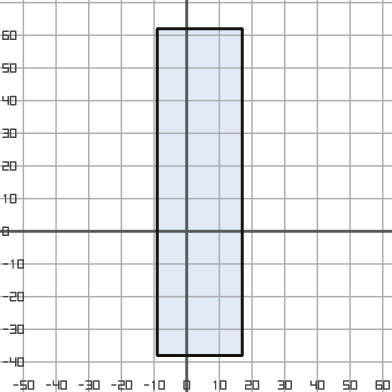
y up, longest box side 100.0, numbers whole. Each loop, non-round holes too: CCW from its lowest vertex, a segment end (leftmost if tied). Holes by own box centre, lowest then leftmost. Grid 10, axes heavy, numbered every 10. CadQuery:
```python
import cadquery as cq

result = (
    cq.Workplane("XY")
    .moveTo(-9.0, -38.0)
    .lineTo(17.0, -38.0)
    .lineTo(17.0, 62.0)
    .lineTo(-9.0, 62.0)
    .close()
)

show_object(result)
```